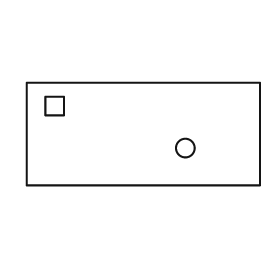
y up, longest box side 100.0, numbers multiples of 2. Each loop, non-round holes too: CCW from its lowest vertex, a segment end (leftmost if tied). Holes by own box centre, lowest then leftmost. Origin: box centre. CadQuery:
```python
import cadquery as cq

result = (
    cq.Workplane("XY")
    .moveTo(-50.0, -22.0)
    .lineTo(50.0, -22.0)
    .lineTo(50.0, 22.0)
    .lineTo(-50.0, 22.0)
    .close()
    .moveTo(18.0, -6.0)
    .circle(4.0)
    .moveTo(-42.0, 8.0)
    .lineTo(-34.0, 8.0)
    .lineTo(-34.0, 16.0)
    .lineTo(-42.0, 16.0)
    .close()
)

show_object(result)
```